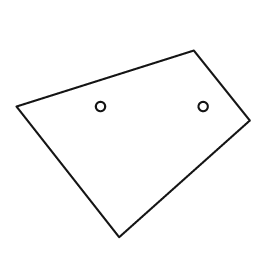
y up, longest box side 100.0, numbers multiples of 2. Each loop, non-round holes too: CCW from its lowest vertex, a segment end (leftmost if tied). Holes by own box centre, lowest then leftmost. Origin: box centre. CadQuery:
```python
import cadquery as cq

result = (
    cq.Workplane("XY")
    .moveTo(-6.0, -40.0)
    .lineTo(50.0, 10.0)
    .lineTo(26.0, 40.0)
    .lineTo(-50.0, 16.0)
    .close()
    .moveTo(-14.0, 16.0)
    .circle(2.0)
    .moveTo(30.0, 16.0)
    .circle(2.0)
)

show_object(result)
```